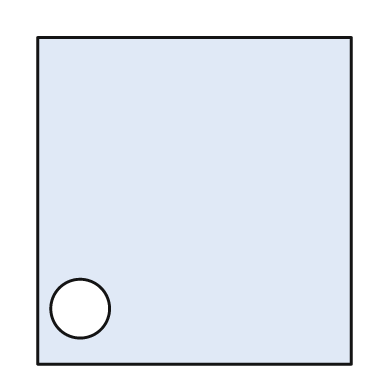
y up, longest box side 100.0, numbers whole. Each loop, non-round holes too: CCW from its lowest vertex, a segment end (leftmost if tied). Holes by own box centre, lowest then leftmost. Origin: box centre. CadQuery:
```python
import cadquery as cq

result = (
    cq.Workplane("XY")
    .moveTo(-48.0, -50.0)
    .lineTo(48.0, -50.0)
    .lineTo(48.0, 50.0)
    .lineTo(-48.0, 50.0)
    .close()
    .moveTo(-35.0, -33.0)
    .circle(9.0)
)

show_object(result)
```